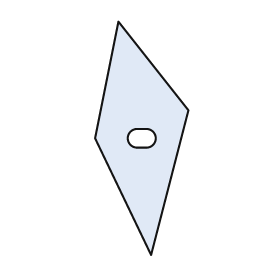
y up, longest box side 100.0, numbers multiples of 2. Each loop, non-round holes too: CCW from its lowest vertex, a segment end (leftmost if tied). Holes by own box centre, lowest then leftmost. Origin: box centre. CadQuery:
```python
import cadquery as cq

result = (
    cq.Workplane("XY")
    .moveTo(4.0, -50.0)
    .lineTo(20.0, 12.0)
    .lineTo(-10.0, 50.0)
    .lineTo(-20.0, 0.0)
    .close()
    .moveTo(-2.0, -4.0)
    .lineTo(2.0, -4.0)
    .threePointArc((6.0, 0.0), (2.0, 4.0))
    .lineTo(-2.0, 4.0)
    .threePointArc((-6.0, 0.0), (-2.0, -4.0))
    .close()
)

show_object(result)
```